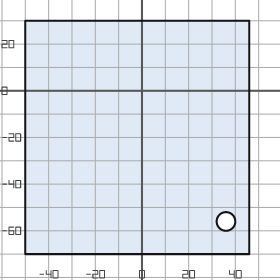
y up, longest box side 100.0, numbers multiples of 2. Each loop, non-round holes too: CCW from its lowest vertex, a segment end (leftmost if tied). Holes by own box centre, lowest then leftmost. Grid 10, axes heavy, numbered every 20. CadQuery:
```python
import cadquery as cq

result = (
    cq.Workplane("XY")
    .moveTo(-50.0, -70.0)
    .lineTo(46.0, -70.0)
    .lineTo(46.0, 30.0)
    .lineTo(-50.0, 30.0)
    .close()
    .moveTo(36.0, -56.0)
    .circle(4.0)
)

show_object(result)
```